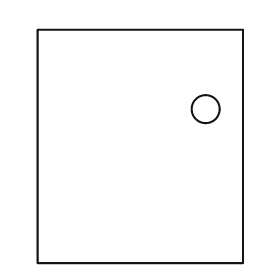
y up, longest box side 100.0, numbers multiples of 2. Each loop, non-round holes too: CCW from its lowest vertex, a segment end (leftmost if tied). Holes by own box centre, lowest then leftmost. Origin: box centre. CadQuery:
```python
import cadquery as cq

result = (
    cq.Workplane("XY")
    .moveTo(-44.0, -50.0)
    .lineTo(44.0, -50.0)
    .lineTo(44.0, 50.0)
    .lineTo(-44.0, 50.0)
    .close()
    .moveTo(28.0, 16.0)
    .circle(6.0)
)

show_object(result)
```